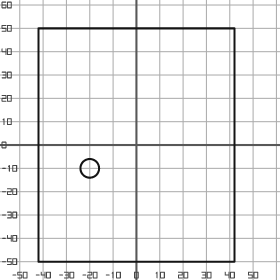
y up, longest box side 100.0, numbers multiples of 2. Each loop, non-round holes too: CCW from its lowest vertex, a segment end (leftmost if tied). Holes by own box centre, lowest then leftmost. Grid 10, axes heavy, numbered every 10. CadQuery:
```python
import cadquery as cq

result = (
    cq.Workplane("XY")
    .moveTo(-42.0, -50.0)
    .lineTo(42.0, -50.0)
    .lineTo(42.0, 50.0)
    .lineTo(-42.0, 50.0)
    .close()
    .moveTo(-20.0, -10.0)
    .circle(4.0)
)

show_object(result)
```